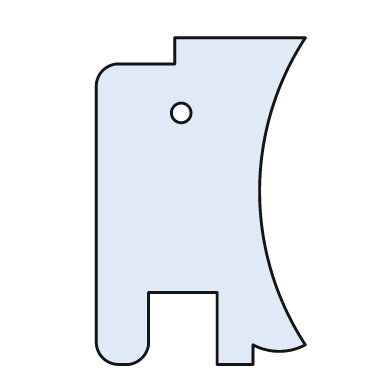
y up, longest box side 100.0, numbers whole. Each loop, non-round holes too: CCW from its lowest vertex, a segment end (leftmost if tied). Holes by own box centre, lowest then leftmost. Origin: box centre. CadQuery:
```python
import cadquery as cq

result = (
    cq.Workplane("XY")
    .moveTo(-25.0, -50.0)
    .lineTo(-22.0, -50.0)
    .threePointArc((-18.0, -48.0), (-16.0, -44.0))
    .lineTo(-16.0, -28.0)
    .lineTo(5.0, -28.0)
    .lineTo(5.0, -50.0)
    .lineTo(16.0, -50.0)
    .lineTo(16.0, -44.0)
    .threePointArc((24.0, -46.0), (32.0, -44.0))
    .threePointArc((18.0, 3.0), (32.0, 50.0))
    .lineTo(-8.0, 50.0)
    .lineTo(-8.0, 42.0)
    .lineTo(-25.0, 42.0)
    .threePointArc((-30.0, 40.0), (-32.0, 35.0))
    .lineTo(-32.0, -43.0)
    .threePointArc((-30.0, -48.0), (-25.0, -50.0))
    .close()
    .moveTo(-6.0, 27.0)
    .circle(3.0)
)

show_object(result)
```